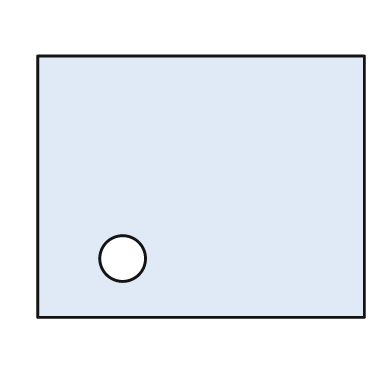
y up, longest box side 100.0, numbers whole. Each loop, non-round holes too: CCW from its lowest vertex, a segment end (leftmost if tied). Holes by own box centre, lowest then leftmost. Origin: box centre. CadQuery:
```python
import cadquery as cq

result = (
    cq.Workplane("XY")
    .moveTo(-50.0, -40.0)
    .lineTo(50.0, -40.0)
    .lineTo(50.0, 40.0)
    .lineTo(-50.0, 40.0)
    .close()
    .moveTo(-24.0, -22.0)
    .circle(7.0)
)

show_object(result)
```